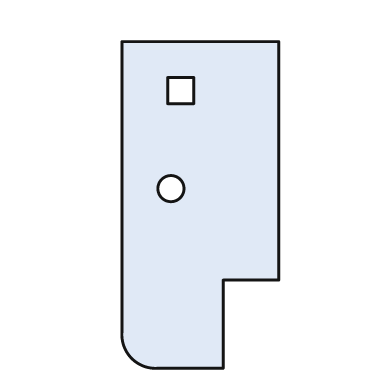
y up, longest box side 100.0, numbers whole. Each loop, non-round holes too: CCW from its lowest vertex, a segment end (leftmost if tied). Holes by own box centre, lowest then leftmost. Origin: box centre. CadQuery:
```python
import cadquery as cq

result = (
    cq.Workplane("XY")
    .moveTo(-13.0, -50.0)
    .lineTo(7.0, -50.0)
    .lineTo(7.0, -23.0)
    .lineTo(24.0, -23.0)
    .lineTo(24.0, 50.0)
    .lineTo(-24.0, 50.0)
    .lineTo(-24.0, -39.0)
    .threePointArc((-21.0, -47.0), (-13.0, -50.0))
    .close()
    .moveTo(-9.0, 5.0)
    .circle(4.0)
    .moveTo(-10.0, 31.0)
    .lineTo(-2.0, 31.0)
    .lineTo(-2.0, 39.0)
    .lineTo(-10.0, 39.0)
    .close()
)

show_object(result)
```